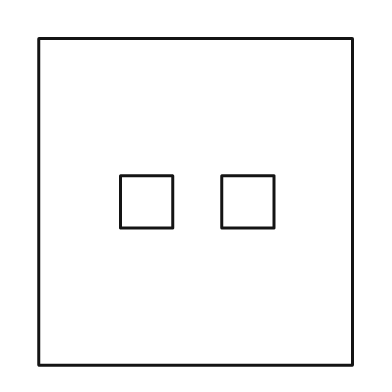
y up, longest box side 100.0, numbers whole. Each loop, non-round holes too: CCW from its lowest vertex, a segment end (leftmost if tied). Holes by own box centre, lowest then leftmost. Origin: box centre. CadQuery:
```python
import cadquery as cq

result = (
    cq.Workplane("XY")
    .moveTo(-48.0, -50.0)
    .lineTo(48.0, -50.0)
    .lineTo(48.0, 50.0)
    .lineTo(-48.0, 50.0)
    .close()
    .moveTo(-23.0, -8.0)
    .lineTo(-7.0, -8.0)
    .lineTo(-7.0, 8.0)
    .lineTo(-23.0, 8.0)
    .close()
    .moveTo(8.0, -8.0)
    .lineTo(24.0, -8.0)
    .lineTo(24.0, 8.0)
    .lineTo(8.0, 8.0)
    .close()
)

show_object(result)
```